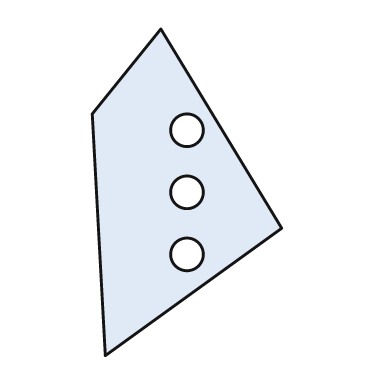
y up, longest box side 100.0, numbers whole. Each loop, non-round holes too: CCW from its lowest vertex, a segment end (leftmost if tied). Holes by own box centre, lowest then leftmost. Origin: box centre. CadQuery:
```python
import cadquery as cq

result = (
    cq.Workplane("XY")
    .moveTo(-25.0, -50.0)
    .lineTo(29.0, -11.0)
    .lineTo(-8.0, 50.0)
    .lineTo(-29.0, 24.0)
    .close()
    .moveTo(0.0, -19.0)
    .circle(5.0)
    .moveTo(0.0, 0.0)
    .circle(5.0)
    .moveTo(0.0, 19.0)
    .circle(5.0)
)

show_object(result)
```